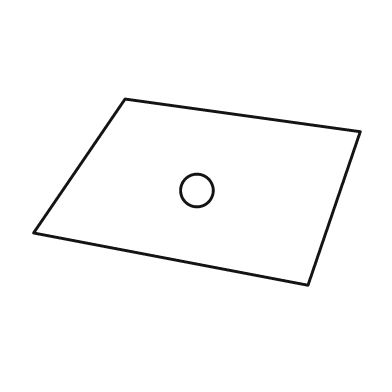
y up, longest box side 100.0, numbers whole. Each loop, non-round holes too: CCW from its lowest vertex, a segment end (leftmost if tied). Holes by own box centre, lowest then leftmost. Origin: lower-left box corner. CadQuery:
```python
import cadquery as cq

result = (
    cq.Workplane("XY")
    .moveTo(84.0, 0.0)
    .lineTo(100.0, 47.0)
    .lineTo(28.0, 57.0)
    .lineTo(0.0, 16.0)
    .close()
    .moveTo(50.0, 29.0)
    .circle(5.0)
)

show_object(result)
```